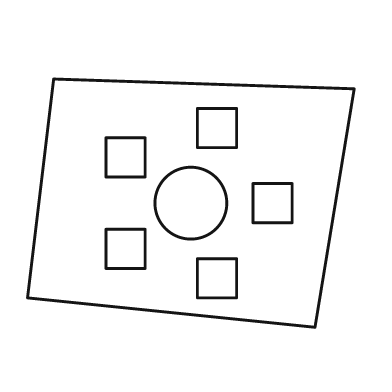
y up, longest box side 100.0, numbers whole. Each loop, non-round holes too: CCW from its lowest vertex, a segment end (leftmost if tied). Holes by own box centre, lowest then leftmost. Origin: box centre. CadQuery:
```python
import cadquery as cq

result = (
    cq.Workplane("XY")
    .moveTo(38.0, -38.0)
    .lineTo(50.0, 35.0)
    .lineTo(-42.0, 38.0)
    .lineTo(-50.0, -29.0)
    .close()
    .moveTo(2.0, -29.0)
    .lineTo(14.0, -29.0)
    .lineTo(14.0, -17.0)
    .lineTo(2.0, -17.0)
    .close()
    .moveTo(-26.0, -20.0)
    .lineTo(-14.0, -20.0)
    .lineTo(-14.0, -8.0)
    .lineTo(-26.0, -8.0)
    .close()
    .moveTo(0.0, 0.0)
    .circle(11.0)
    .moveTo(19.0, -6.0)
    .lineTo(31.0, -6.0)
    .lineTo(31.0, 6.0)
    .lineTo(19.0, 6.0)
    .close()
    .moveTo(-26.0, 8.0)
    .lineTo(-14.0, 8.0)
    .lineTo(-14.0, 20.0)
    .lineTo(-26.0, 20.0)
    .close()
    .moveTo(2.0, 17.0)
    .lineTo(14.0, 17.0)
    .lineTo(14.0, 29.0)
    .lineTo(2.0, 29.0)
    .close()
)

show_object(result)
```